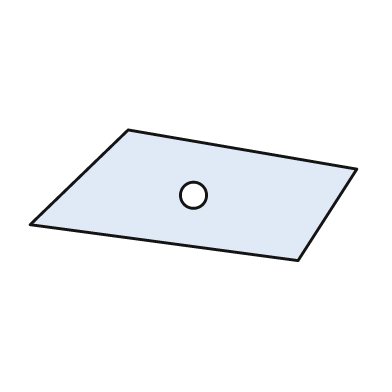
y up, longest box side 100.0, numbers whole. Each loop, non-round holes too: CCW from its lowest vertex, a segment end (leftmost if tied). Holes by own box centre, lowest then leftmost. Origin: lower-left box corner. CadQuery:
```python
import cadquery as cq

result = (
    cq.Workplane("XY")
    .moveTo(82.0, 0.0)
    .lineTo(100.0, 28.0)
    .lineTo(30.0, 40.0)
    .lineTo(0.0, 11.0)
    .close()
    .moveTo(50.0, 20.0)
    .circle(4.0)
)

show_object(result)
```